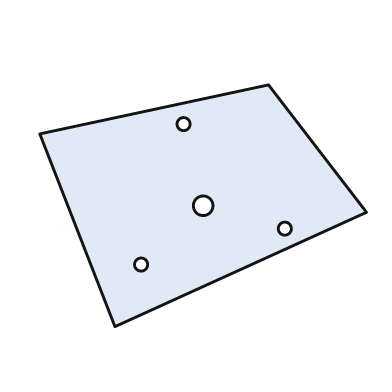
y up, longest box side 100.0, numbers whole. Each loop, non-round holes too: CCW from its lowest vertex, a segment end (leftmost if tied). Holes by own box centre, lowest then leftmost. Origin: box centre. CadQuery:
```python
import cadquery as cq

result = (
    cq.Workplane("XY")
    .moveTo(-27.0, -37.0)
    .lineTo(50.0, -2.0)
    .lineTo(20.0, 37.0)
    .lineTo(-50.0, 22.0)
    .close()
    .moveTo(-19.0, -18.0)
    .circle(2.0)
    .moveTo(25.0, -7.0)
    .circle(2.0)
    .moveTo(0.0, 0.0)
    .circle(3.0)
    .moveTo(-6.0, 25.0)
    .circle(2.0)
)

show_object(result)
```